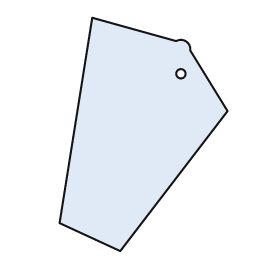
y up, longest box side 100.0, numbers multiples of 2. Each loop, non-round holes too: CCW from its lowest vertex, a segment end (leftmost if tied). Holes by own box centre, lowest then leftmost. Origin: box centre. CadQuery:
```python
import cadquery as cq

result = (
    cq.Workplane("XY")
    .moveTo(-10.0, -50.0)
    .lineTo(36.0, 10.0)
    .lineTo(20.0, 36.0)
    .threePointArc((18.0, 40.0), (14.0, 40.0))
    .lineTo(-22.0, 50.0)
    .lineTo(-36.0, -38.0)
    .close()
    .moveTo(16.0, 26.0)
    .circle(2.0)
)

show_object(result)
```